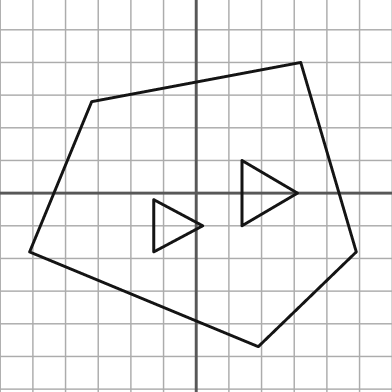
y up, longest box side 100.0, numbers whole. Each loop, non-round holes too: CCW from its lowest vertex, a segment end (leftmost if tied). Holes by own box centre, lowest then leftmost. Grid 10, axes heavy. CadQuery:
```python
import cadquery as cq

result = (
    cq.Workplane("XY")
    .moveTo(19.0, -47.0)
    .lineTo(49.0, -18.0)
    .lineTo(32.0, 40.0)
    .lineTo(-32.0, 28.0)
    .lineTo(-51.0, -18.0)
    .close()
    .moveTo(-13.0, -18.0)
    .lineTo(2.0, -10.0)
    .lineTo(-13.0, -2.0)
    .close()
    .moveTo(14.0, -10.0)
    .lineTo(31.0, 0.0)
    .lineTo(14.0, 10.0)
    .close()
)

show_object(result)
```